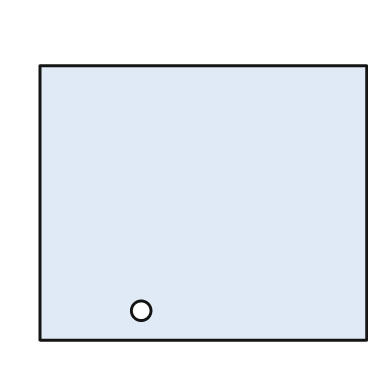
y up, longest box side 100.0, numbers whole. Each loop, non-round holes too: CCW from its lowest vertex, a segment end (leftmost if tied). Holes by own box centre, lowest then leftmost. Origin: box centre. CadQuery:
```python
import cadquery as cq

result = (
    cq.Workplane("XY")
    .moveTo(-50.0, -42.0)
    .lineTo(50.0, -42.0)
    .lineTo(50.0, 42.0)
    .lineTo(-50.0, 42.0)
    .close()
    .moveTo(-19.0, -33.0)
    .circle(3.0)
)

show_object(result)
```